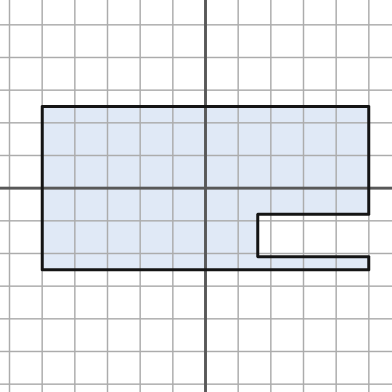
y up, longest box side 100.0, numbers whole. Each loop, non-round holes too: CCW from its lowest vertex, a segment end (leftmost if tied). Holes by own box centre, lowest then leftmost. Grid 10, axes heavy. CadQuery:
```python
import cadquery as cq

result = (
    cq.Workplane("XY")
    .moveTo(-50.0, -25.0)
    .lineTo(50.0, -25.0)
    .lineTo(50.0, -21.0)
    .lineTo(16.0, -21.0)
    .lineTo(16.0, -8.0)
    .lineTo(50.0, -8.0)
    .lineTo(50.0, 25.0)
    .lineTo(-50.0, 25.0)
    .close()
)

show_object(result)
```